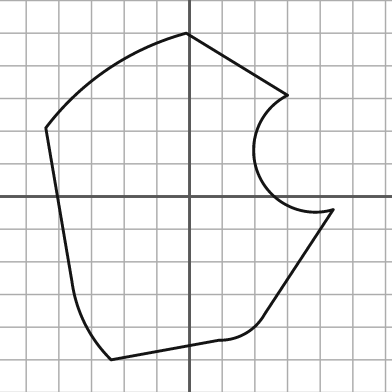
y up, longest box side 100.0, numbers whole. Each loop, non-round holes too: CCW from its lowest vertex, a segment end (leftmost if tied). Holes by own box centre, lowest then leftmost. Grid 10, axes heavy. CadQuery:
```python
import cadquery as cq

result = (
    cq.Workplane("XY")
    .moveTo(-24.0, -50.0)
    .lineTo(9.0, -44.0)
    .threePointArc((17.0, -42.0), (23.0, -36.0))
    .lineTo(44.0, -4.0)
    .threePointArc((21.0, 7.0), (30.0, 31.0))
    .lineTo(-1.0, 50.0)
    .threePointArc((-25.0, 39.0), (-44.0, 21.0))
    .lineTo(-36.0, -26.0)
    .threePointArc((-32.0, -39.0), (-24.0, -50.0))
    .close()
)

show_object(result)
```